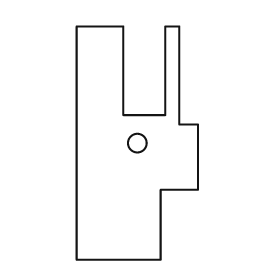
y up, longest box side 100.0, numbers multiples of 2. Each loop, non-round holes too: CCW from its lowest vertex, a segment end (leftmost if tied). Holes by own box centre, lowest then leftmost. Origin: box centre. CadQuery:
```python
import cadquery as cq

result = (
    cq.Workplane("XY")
    .moveTo(-26.0, -50.0)
    .lineTo(10.0, -50.0)
    .lineTo(10.0, -20.0)
    .lineTo(26.0, -20.0)
    .lineTo(26.0, 8.0)
    .lineTo(18.0, 8.0)
    .lineTo(18.0, 50.0)
    .lineTo(12.0, 50.0)
    .lineTo(12.0, 12.0)
    .lineTo(-6.0, 12.0)
    .lineTo(-6.0, 50.0)
    .lineTo(-26.0, 50.0)
    .close()
    .moveTo(0.0, 0.0)
    .circle(4.0)
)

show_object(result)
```